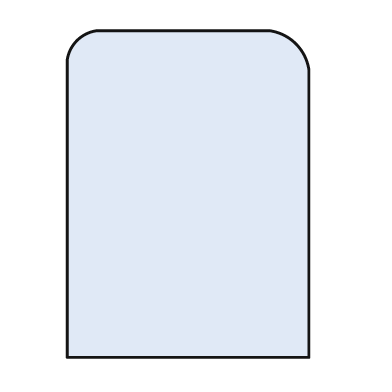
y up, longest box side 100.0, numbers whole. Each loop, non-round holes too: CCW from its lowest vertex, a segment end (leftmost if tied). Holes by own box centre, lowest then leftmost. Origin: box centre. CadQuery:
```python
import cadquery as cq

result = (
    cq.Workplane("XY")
    .moveTo(-37.0, -50.0)
    .lineTo(37.0, -50.0)
    .lineTo(37.0, 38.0)
    .threePointArc((33.0, 46.0), (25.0, 50.0))
    .lineTo(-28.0, 50.0)
    .threePointArc((-34.0, 47.0), (-37.0, 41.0))
    .close()
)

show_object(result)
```